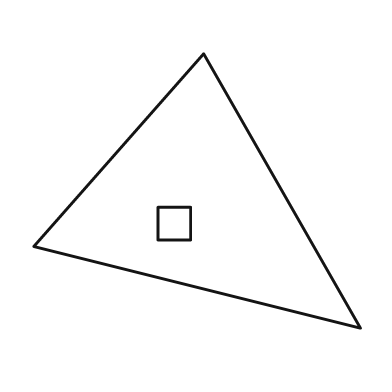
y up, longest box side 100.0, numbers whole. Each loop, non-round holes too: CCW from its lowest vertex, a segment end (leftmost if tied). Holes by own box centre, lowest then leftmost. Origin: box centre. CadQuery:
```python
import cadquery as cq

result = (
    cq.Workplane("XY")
    .moveTo(50.0, -42.0)
    .lineTo(2.0, 42.0)
    .lineTo(-50.0, -17.0)
    .close()
    .moveTo(-12.0, -15.0)
    .lineTo(-2.0, -15.0)
    .lineTo(-2.0, -5.0)
    .lineTo(-12.0, -5.0)
    .close()
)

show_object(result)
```